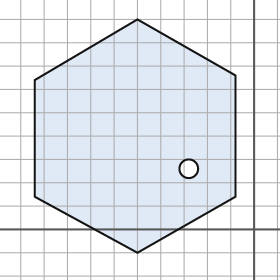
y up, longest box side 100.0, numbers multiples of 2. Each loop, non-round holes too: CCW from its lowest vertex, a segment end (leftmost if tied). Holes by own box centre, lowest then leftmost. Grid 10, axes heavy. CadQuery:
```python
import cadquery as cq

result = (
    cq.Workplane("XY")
    .moveTo(-50.0, -10.0)
    .lineTo(-8.0, 14.0)
    .lineTo(-8.0, 66.0)
    .lineTo(-50.0, 90.0)
    .lineTo(-94.0, 64.0)
    .lineTo(-94.0, 14.0)
    .close()
    .moveTo(-28.0, 26.0)
    .circle(4.0)
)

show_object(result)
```